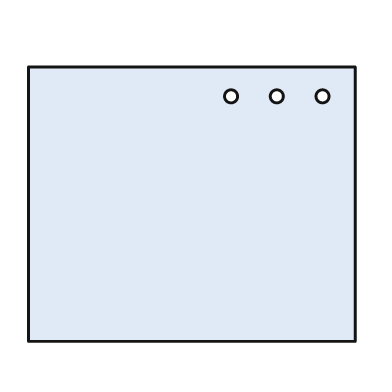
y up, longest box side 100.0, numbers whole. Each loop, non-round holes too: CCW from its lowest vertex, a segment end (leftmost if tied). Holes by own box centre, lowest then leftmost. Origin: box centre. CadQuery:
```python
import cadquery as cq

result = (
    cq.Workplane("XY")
    .moveTo(-50.0, -42.0)
    .lineTo(50.0, -42.0)
    .lineTo(50.0, 42.0)
    .lineTo(-50.0, 42.0)
    .close()
    .moveTo(12.0, 33.0)
    .circle(2.0)
    .moveTo(26.0, 33.0)
    .circle(2.0)
    .moveTo(40.0, 33.0)
    .circle(2.0)
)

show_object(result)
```